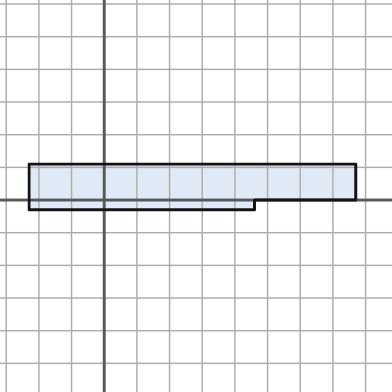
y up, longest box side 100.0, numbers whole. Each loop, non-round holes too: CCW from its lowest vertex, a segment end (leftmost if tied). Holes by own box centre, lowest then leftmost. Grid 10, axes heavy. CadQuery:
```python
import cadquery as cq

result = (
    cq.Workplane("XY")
    .moveTo(-23.0, -3.0)
    .lineTo(46.0, -3.0)
    .lineTo(46.0, 0.0)
    .lineTo(77.0, 0.0)
    .lineTo(77.0, 11.0)
    .lineTo(-23.0, 11.0)
    .close()
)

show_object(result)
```